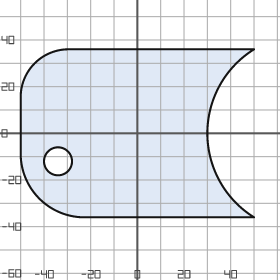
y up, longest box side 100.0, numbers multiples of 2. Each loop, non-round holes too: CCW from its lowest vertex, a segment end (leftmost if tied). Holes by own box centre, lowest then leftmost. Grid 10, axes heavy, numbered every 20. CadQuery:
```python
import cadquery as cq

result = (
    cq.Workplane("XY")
    .moveTo(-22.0, -36.0)
    .lineTo(50.0, -36.0)
    .threePointArc((30.0, 0.0), (50.0, 36.0))
    .lineTo(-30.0, 36.0)
    .threePointArc((-44.0, 30.0), (-50.0, 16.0))
    .lineTo(-50.0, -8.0)
    .threePointArc((-42.0, -28.0), (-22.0, -36.0))
    .close()
    .moveTo(-34.0, -12.0)
    .circle(6.0)
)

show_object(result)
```